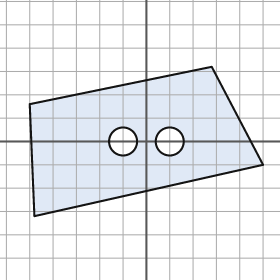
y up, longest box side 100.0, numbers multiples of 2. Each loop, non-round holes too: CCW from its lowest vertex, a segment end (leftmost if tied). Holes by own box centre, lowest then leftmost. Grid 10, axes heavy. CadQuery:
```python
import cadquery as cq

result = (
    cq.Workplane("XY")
    .moveTo(-48.0, -32.0)
    .lineTo(50.0, -10.0)
    .lineTo(28.0, 32.0)
    .lineTo(-50.0, 16.0)
    .close()
    .moveTo(-10.0, 0.0)
    .circle(6.0)
    .moveTo(10.0, 0.0)
    .circle(6.0)
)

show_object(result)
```